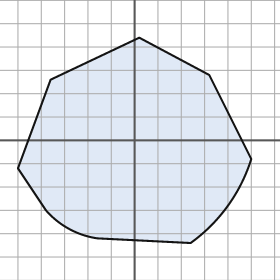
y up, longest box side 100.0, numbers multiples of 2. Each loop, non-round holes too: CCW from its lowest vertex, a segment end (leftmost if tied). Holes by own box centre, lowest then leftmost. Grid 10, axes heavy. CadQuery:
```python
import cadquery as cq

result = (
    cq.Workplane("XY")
    .moveTo(24.0, -44.0)
    .threePointArc((40.0, -28.0), (50.0, -8.0))
    .lineTo(32.0, 28.0)
    .lineTo(2.0, 44.0)
    .lineTo(-36.0, 26.0)
    .lineTo(-50.0, -12.0)
    .lineTo(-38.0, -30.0)
    .threePointArc((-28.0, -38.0), (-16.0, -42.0))
    .close()
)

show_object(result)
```